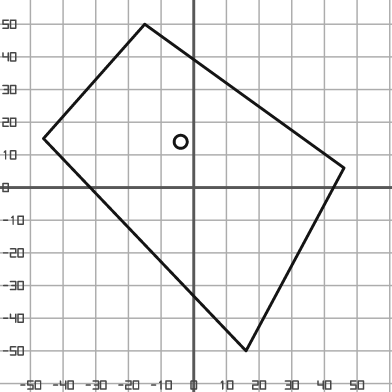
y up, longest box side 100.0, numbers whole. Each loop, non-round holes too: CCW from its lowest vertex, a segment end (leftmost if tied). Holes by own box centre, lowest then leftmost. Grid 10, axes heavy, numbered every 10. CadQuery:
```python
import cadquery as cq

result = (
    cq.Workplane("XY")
    .moveTo(16.0, -50.0)
    .lineTo(46.0, 6.0)
    .lineTo(-15.0, 50.0)
    .lineTo(-46.0, 15.0)
    .close()
    .moveTo(-4.0, 14.0)
    .circle(2.0)
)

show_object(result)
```